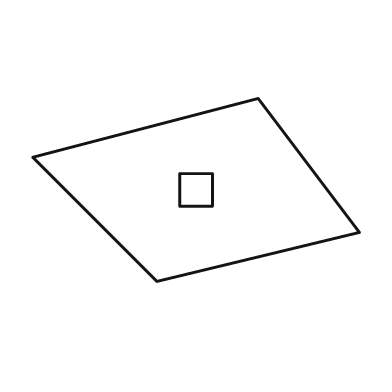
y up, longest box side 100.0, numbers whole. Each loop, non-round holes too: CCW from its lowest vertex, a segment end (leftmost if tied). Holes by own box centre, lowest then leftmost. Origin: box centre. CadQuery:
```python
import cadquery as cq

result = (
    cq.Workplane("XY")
    .moveTo(-12.0, -28.0)
    .lineTo(50.0, -13.0)
    .lineTo(19.0, 28.0)
    .lineTo(-50.0, 10.0)
    .close()
    .moveTo(-5.0, -5.0)
    .lineTo(5.0, -5.0)
    .lineTo(5.0, 5.0)
    .lineTo(-5.0, 5.0)
    .close()
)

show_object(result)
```